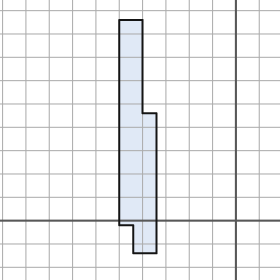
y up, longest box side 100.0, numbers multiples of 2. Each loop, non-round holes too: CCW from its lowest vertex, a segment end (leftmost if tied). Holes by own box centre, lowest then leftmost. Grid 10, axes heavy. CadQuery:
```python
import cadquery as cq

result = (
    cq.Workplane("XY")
    .moveTo(-44.0, -14.0)
    .lineTo(-34.0, -14.0)
    .lineTo(-34.0, 46.0)
    .lineTo(-40.0, 46.0)
    .lineTo(-40.0, 86.0)
    .lineTo(-50.0, 86.0)
    .lineTo(-50.0, -2.0)
    .lineTo(-44.0, -2.0)
    .close()
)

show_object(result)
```